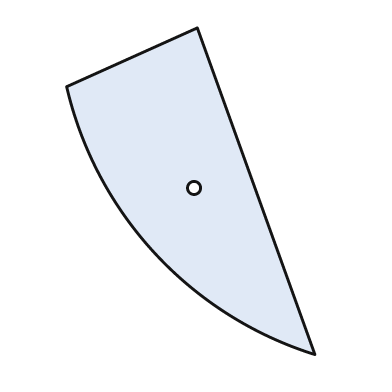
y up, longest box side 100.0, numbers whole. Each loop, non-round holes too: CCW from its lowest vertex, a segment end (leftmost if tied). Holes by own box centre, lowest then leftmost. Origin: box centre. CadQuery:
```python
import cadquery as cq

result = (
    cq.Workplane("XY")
    .moveTo(38.0, -50.0)
    .lineTo(2.0, 50.0)
    .lineTo(-38.0, 32.0)
    .threePointArc((-11.0, -19.0), (38.0, -50.0))
    .close()
    .moveTo(1.0, 1.0)
    .circle(2.0)
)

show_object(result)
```